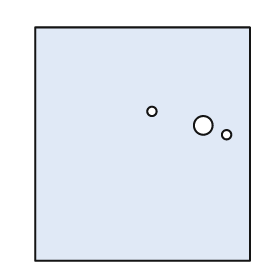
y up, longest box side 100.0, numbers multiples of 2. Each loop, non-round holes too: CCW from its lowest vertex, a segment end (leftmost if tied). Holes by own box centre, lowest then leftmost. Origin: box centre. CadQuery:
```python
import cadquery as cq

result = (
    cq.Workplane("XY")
    .moveTo(-46.0, -50.0)
    .lineTo(46.0, -50.0)
    .lineTo(46.0, 50.0)
    .lineTo(-46.0, 50.0)
    .close()
    .moveTo(36.0, 4.0)
    .circle(2.0)
    .moveTo(26.0, 8.0)
    .circle(4.0)
    .moveTo(4.0, 14.0)
    .circle(2.0)
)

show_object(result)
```